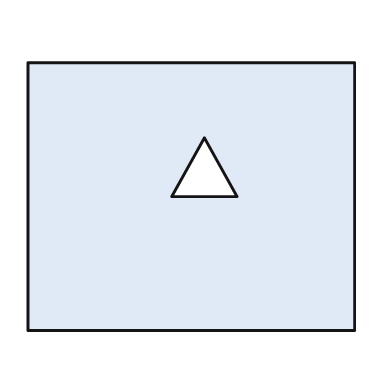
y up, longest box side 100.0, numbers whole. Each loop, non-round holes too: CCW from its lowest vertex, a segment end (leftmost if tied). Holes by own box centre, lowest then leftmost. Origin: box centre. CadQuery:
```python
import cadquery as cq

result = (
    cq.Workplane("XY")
    .moveTo(-50.0, -41.0)
    .lineTo(50.0, -41.0)
    .lineTo(50.0, 41.0)
    .lineTo(-50.0, 41.0)
    .close()
    .moveTo(-6.0, 0.0)
    .lineTo(14.0, 0.0)
    .lineTo(4.0, 18.0)
    .close()
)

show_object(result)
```